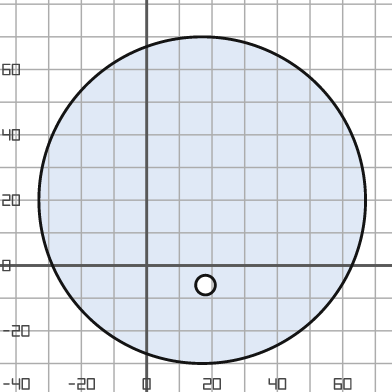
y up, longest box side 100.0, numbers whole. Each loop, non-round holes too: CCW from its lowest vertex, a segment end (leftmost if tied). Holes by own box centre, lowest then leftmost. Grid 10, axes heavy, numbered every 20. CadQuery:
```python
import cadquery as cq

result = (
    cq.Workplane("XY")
    .moveTo(17.0, 20.0)
    .circle(50.0)
    .moveTo(18.0, -6.0)
    .circle(3.0)
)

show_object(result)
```